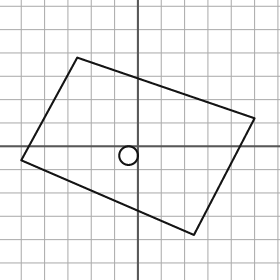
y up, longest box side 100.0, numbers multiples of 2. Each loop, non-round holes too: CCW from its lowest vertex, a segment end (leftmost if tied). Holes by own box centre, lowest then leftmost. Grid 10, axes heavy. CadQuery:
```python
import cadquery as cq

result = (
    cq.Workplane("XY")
    .moveTo(24.0, -38.0)
    .lineTo(50.0, 12.0)
    .lineTo(-26.0, 38.0)
    .lineTo(-50.0, -6.0)
    .close()
    .moveTo(-4.0, -4.0)
    .circle(4.0)
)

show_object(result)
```